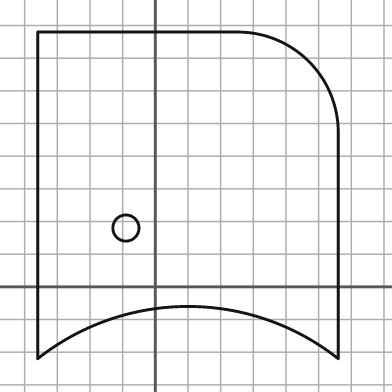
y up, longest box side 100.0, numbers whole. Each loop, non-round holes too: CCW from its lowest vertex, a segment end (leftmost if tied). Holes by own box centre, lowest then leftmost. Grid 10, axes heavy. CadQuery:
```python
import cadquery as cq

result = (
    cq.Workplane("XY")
    .moveTo(-36.0, -22.0)
    .threePointArc((10.0, -6.0), (56.0, -22.0))
    .lineTo(56.0, 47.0)
    .threePointArc((47.0, 69.0), (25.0, 78.0))
    .lineTo(-36.0, 78.0)
    .close()
    .moveTo(-9.0, 18.0)
    .circle(4.0)
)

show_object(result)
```